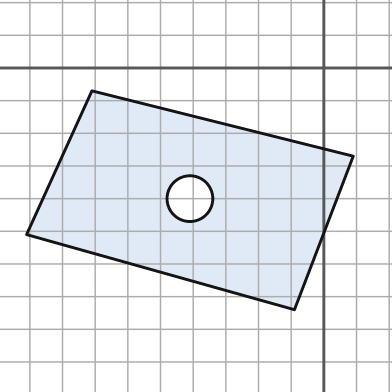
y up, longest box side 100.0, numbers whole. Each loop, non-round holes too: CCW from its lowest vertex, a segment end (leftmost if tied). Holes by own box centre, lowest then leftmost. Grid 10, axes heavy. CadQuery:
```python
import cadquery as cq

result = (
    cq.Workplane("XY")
    .moveTo(-9.0, -74.0)
    .lineTo(9.0, -27.0)
    .lineTo(-71.0, -7.0)
    .lineTo(-91.0, -51.0)
    .close()
    .moveTo(-41.0, -40.0)
    .circle(7.0)
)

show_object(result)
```